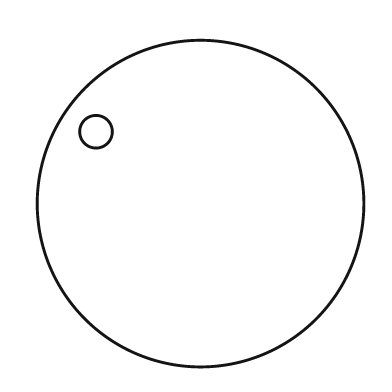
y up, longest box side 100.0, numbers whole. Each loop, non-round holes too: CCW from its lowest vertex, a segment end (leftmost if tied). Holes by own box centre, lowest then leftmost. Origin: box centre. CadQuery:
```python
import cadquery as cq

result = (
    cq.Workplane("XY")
    .moveTo(0.0, 0.0)
    .circle(50.0)
    .moveTo(-32.0, 22.0)
    .circle(5.0)
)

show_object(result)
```